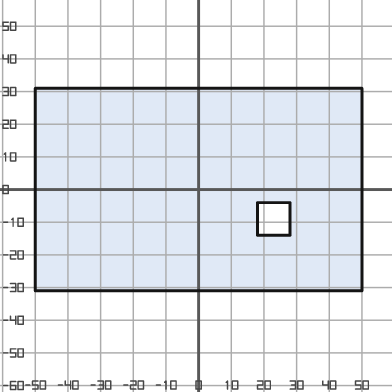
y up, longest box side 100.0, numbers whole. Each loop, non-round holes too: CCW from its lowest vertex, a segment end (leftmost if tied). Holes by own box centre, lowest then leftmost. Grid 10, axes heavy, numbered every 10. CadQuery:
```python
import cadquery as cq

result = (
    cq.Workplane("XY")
    .moveTo(-50.0, -31.0)
    .lineTo(50.0, -31.0)
    .lineTo(50.0, 31.0)
    .lineTo(-50.0, 31.0)
    .close()
    .moveTo(18.0, -14.0)
    .lineTo(28.0, -14.0)
    .lineTo(28.0, -4.0)
    .lineTo(18.0, -4.0)
    .close()
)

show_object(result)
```